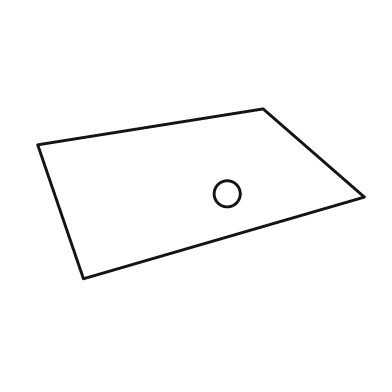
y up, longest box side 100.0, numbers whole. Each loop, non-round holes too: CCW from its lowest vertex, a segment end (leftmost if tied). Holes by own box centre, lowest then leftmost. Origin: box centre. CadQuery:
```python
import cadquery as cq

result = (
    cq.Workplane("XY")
    .moveTo(-36.0, -26.0)
    .lineTo(50.0, -1.0)
    .lineTo(19.0, 26.0)
    .lineTo(-50.0, 15.0)
    .close()
    .moveTo(8.0, 0.0)
    .circle(4.0)
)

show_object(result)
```